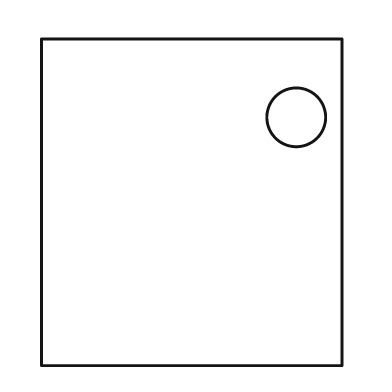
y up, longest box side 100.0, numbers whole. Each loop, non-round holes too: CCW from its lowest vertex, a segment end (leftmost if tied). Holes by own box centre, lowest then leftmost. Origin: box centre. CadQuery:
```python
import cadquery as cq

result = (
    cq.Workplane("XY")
    .moveTo(-46.0, -50.0)
    .lineTo(46.0, -50.0)
    .lineTo(46.0, 50.0)
    .lineTo(-46.0, 50.0)
    .close()
    .moveTo(32.0, 26.0)
    .circle(9.0)
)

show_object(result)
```